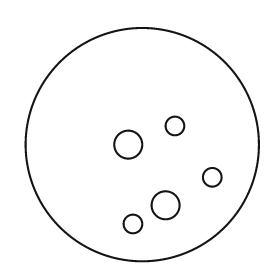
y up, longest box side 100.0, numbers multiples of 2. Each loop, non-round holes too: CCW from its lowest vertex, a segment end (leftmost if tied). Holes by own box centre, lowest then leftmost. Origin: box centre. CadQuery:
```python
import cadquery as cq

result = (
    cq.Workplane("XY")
    .moveTo(0.0, 0.0)
    .circle(50.0)
    .moveTo(-4.0, -34.0)
    .circle(4.0)
    .moveTo(10.0, -26.0)
    .circle(6.0)
    .moveTo(30.0, -14.0)
    .circle(4.0)
    .moveTo(-6.0, 0.0)
    .circle(6.0)
    .moveTo(14.0, 8.0)
    .circle(4.0)
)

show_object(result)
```